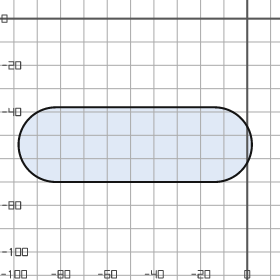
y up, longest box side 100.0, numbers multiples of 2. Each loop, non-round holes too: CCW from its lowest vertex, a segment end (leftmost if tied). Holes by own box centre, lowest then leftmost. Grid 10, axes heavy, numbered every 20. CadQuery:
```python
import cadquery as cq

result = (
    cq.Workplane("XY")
    .moveTo(-82.0, -70.0)
    .lineTo(-14.0, -70.0)
    .threePointArc((2.0, -54.0), (-14.0, -38.0))
    .lineTo(-82.0, -38.0)
    .threePointArc((-98.0, -54.0), (-82.0, -70.0))
    .close()
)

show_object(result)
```